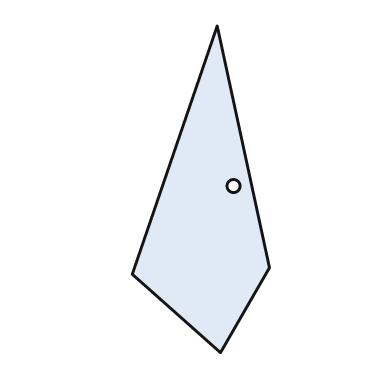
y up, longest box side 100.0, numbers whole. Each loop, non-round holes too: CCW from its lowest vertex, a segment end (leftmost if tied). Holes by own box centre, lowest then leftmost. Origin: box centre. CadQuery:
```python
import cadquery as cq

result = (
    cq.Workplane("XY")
    .moveTo(6.0, -50.0)
    .lineTo(21.0, -24.0)
    .lineTo(5.0, 50.0)
    .lineTo(-21.0, -26.0)
    .close()
    .moveTo(10.0, 1.0)
    .circle(2.0)
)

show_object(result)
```